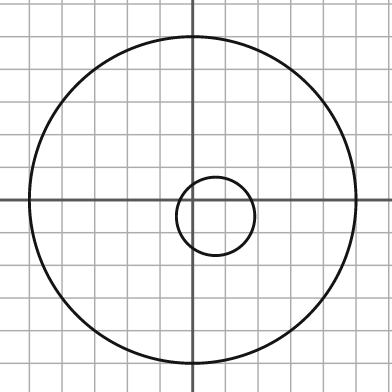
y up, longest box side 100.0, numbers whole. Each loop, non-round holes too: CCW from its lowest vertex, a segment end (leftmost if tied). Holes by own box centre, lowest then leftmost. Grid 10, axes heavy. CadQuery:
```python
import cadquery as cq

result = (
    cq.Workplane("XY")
    .moveTo(0.0, 0.0)
    .circle(50.0)
    .moveTo(7.0, -5.0)
    .circle(12.0)
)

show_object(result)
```